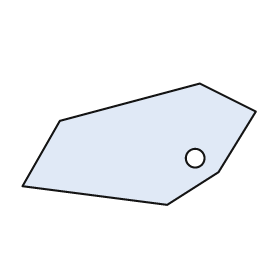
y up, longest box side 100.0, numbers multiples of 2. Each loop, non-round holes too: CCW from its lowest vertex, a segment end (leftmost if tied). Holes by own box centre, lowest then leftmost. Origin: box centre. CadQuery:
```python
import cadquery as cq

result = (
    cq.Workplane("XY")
    .moveTo(12.0, -26.0)
    .lineTo(34.0, -12.0)
    .lineTo(50.0, 14.0)
    .lineTo(26.0, 26.0)
    .lineTo(-34.0, 10.0)
    .lineTo(-50.0, -18.0)
    .close()
    .moveTo(24.0, -6.0)
    .circle(4.0)
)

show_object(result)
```